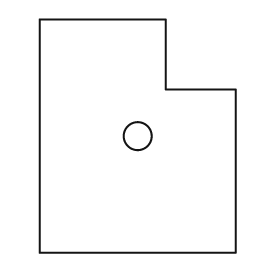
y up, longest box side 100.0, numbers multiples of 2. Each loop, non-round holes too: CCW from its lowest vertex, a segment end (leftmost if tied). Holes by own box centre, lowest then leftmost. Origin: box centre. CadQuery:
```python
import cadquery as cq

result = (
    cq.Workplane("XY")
    .moveTo(-42.0, -50.0)
    .lineTo(42.0, -50.0)
    .lineTo(42.0, 20.0)
    .lineTo(12.0, 20.0)
    .lineTo(12.0, 50.0)
    .lineTo(-42.0, 50.0)
    .close()
    .moveTo(0.0, 0.0)
    .circle(6.0)
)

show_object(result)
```